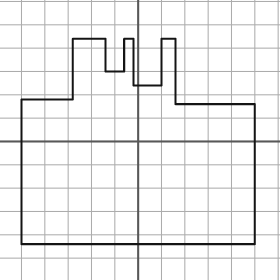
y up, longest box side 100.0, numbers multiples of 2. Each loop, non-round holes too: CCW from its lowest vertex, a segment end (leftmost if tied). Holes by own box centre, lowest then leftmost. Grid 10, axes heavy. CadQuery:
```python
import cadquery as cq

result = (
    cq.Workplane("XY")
    .moveTo(-50.0, -44.0)
    .lineTo(50.0, -44.0)
    .lineTo(50.0, 16.0)
    .lineTo(16.0, 16.0)
    .lineTo(16.0, 44.0)
    .lineTo(10.0, 44.0)
    .lineTo(10.0, 24.0)
    .lineTo(-2.0, 24.0)
    .lineTo(-2.0, 44.0)
    .lineTo(-6.0, 44.0)
    .lineTo(-6.0, 30.0)
    .lineTo(-14.0, 30.0)
    .lineTo(-14.0, 44.0)
    .lineTo(-28.0, 44.0)
    .lineTo(-28.0, 18.0)
    .lineTo(-50.0, 18.0)
    .close()
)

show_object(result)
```